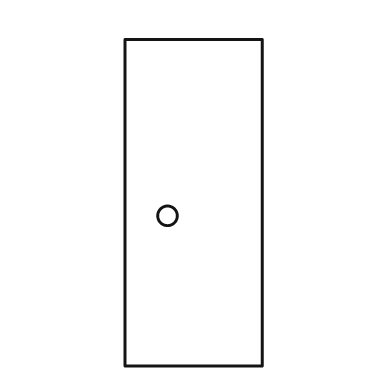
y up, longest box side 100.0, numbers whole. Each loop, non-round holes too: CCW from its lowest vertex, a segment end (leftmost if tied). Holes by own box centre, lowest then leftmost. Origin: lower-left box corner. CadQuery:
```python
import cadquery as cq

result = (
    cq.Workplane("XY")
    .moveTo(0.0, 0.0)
    .lineTo(42.0, 0.0)
    .lineTo(42.0, 100.0)
    .lineTo(0.0, 100.0)
    .close()
    .moveTo(13.0, 46.0)
    .circle(3.0)
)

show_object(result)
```